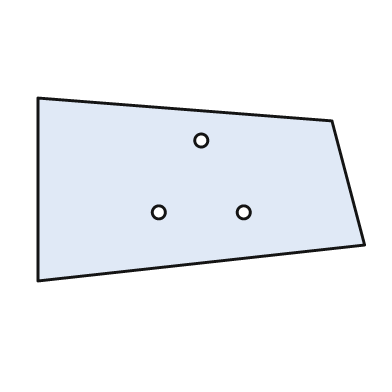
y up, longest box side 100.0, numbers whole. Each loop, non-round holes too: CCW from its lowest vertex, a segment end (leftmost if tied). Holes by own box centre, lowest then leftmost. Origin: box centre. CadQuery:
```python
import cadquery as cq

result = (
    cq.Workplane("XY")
    .moveTo(-50.0, -28.0)
    .lineTo(50.0, -17.0)
    .lineTo(40.0, 21.0)
    .lineTo(-50.0, 28.0)
    .close()
    .moveTo(-13.0, -7.0)
    .circle(2.0)
    .moveTo(13.0, -7.0)
    .circle(2.0)
    .moveTo(0.0, 15.0)
    .circle(2.0)
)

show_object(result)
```